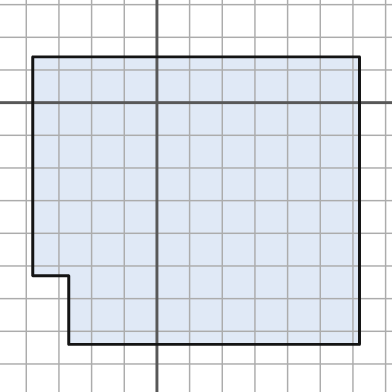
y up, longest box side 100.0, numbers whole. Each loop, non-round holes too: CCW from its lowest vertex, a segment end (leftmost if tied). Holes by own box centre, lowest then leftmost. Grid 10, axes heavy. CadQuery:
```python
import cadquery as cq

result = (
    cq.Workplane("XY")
    .moveTo(-27.0, -74.0)
    .lineTo(62.0, -74.0)
    .lineTo(62.0, 14.0)
    .lineTo(-38.0, 14.0)
    .lineTo(-38.0, -53.0)
    .lineTo(-27.0, -53.0)
    .close()
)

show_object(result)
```